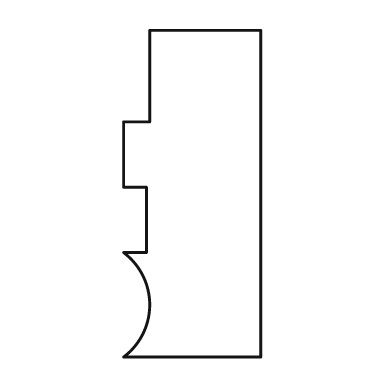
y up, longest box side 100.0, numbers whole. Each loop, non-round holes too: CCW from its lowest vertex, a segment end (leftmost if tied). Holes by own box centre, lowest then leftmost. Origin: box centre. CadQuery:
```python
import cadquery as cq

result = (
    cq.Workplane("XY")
    .moveTo(-21.0, -50.0)
    .lineTo(21.0, -50.0)
    .lineTo(21.0, 50.0)
    .lineTo(-13.0, 50.0)
    .lineTo(-13.0, 22.0)
    .lineTo(-21.0, 22.0)
    .lineTo(-21.0, 2.0)
    .lineTo(-14.0, 2.0)
    .lineTo(-14.0, -18.0)
    .lineTo(-21.0, -18.0)
    .threePointArc((-13.0, -34.0), (-21.0, -50.0))
    .close()
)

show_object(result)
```